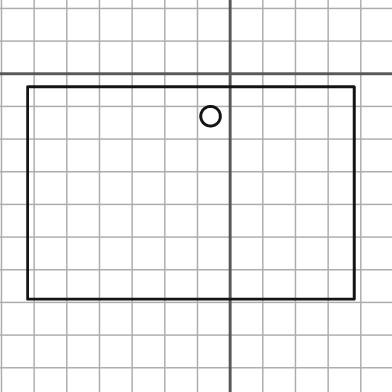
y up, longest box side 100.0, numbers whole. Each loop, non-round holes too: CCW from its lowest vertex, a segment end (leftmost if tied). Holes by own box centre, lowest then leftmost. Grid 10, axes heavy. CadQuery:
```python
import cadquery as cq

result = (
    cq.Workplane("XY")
    .moveTo(-62.0, -69.0)
    .lineTo(38.0, -69.0)
    .lineTo(38.0, -4.0)
    .lineTo(-62.0, -4.0)
    .close()
    .moveTo(-6.0, -13.0)
    .circle(3.0)
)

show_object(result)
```